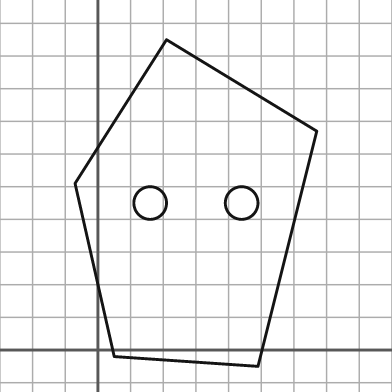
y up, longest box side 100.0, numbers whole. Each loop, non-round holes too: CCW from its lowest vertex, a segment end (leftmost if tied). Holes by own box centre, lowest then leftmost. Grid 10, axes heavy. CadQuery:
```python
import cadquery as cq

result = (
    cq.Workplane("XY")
    .moveTo(49.0, -5.0)
    .lineTo(67.0, 67.0)
    .lineTo(21.0, 95.0)
    .lineTo(-7.0, 51.0)
    .lineTo(5.0, -2.0)
    .close()
    .moveTo(16.0, 45.0)
    .circle(5.0)
    .moveTo(44.0, 45.0)
    .circle(5.0)
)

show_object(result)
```